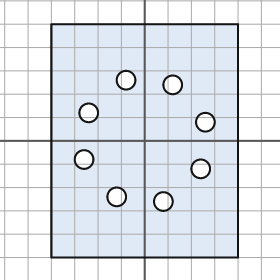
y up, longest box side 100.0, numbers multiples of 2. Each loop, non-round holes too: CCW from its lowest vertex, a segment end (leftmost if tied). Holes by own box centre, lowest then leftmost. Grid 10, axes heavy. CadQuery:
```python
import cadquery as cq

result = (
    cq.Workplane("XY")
    .moveTo(-40.0, -50.0)
    .lineTo(40.0, -50.0)
    .lineTo(40.0, 50.0)
    .lineTo(-40.0, 50.0)
    .close()
    .moveTo(8.0, -26.0)
    .circle(4.0)
    .moveTo(-12.0, -24.0)
    .circle(4.0)
    .moveTo(24.0, -12.0)
    .circle(4.0)
    .moveTo(-26.0, -8.0)
    .circle(4.0)
    .moveTo(26.0, 8.0)
    .circle(4.0)
    .moveTo(-24.0, 12.0)
    .circle(4.0)
    .moveTo(12.0, 24.0)
    .circle(4.0)
    .moveTo(-8.0, 26.0)
    .circle(4.0)
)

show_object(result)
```